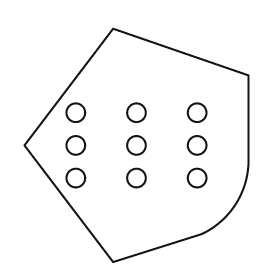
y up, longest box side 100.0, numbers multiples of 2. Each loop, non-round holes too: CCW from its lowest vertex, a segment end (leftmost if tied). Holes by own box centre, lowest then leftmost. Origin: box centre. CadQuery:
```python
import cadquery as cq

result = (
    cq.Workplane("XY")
    .moveTo(-10.0, -50.0)
    .lineTo(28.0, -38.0)
    .threePointArc((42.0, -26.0), (48.0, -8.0))
    .lineTo(48.0, 30.0)
    .lineTo(-10.0, 50.0)
    .lineTo(-48.0, 0.0)
    .close()
    .moveTo(-26.0, -14.0)
    .circle(4.0)
    .moveTo(0.0, -14.0)
    .circle(4.0)
    .moveTo(26.0, -14.0)
    .circle(4.0)
    .moveTo(-26.0, 0.0)
    .circle(4.0)
    .moveTo(0.0, 0.0)
    .circle(4.0)
    .moveTo(26.0, 0.0)
    .circle(4.0)
    .moveTo(-26.0, 14.0)
    .circle(4.0)
    .moveTo(0.0, 14.0)
    .circle(4.0)
    .moveTo(26.0, 14.0)
    .circle(4.0)
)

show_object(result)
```